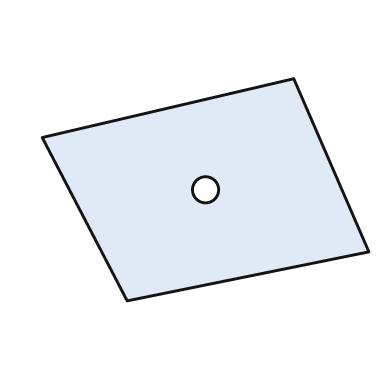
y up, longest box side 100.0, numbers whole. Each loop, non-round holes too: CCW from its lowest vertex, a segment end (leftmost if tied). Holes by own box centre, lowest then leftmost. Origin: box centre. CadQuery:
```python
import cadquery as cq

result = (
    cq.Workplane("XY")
    .moveTo(-24.0, -34.0)
    .lineTo(50.0, -19.0)
    .lineTo(27.0, 34.0)
    .lineTo(-50.0, 16.0)
    .close()
    .moveTo(0.0, 0.0)
    .circle(4.0)
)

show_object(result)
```